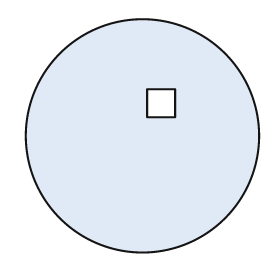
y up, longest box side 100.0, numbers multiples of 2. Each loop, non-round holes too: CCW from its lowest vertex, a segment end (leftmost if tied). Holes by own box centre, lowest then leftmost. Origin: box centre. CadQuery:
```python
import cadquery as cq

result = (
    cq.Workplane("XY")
    .moveTo(0.0, 0.0)
    .circle(50.0)
    .moveTo(2.0, 8.0)
    .lineTo(14.0, 8.0)
    .lineTo(14.0, 20.0)
    .lineTo(2.0, 20.0)
    .close()
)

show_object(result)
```